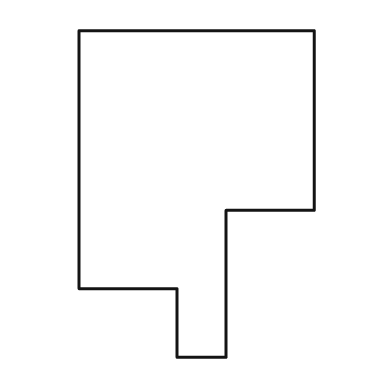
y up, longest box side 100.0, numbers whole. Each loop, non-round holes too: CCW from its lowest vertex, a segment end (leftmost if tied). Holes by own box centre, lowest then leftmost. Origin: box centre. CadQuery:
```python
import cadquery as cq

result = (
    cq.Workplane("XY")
    .moveTo(-6.0, -50.0)
    .lineTo(9.0, -50.0)
    .lineTo(9.0, -5.0)
    .lineTo(36.0, -5.0)
    .lineTo(36.0, 50.0)
    .lineTo(-36.0, 50.0)
    .lineTo(-36.0, -29.0)
    .lineTo(-6.0, -29.0)
    .close()
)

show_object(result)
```